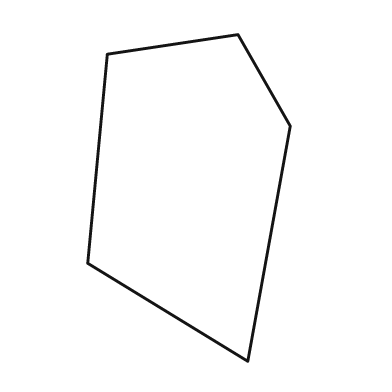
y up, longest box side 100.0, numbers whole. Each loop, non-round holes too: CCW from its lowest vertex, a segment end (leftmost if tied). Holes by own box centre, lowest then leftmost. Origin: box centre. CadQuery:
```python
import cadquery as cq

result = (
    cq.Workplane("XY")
    .moveTo(18.0, -50.0)
    .lineTo(31.0, 22.0)
    .lineTo(15.0, 50.0)
    .lineTo(-25.0, 44.0)
    .lineTo(-31.0, -20.0)
    .close()
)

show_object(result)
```